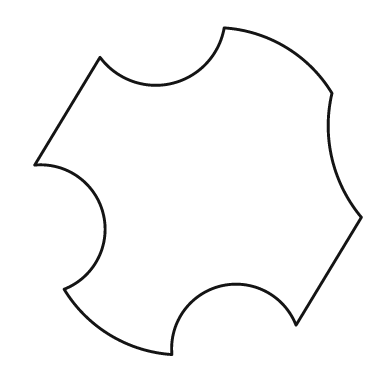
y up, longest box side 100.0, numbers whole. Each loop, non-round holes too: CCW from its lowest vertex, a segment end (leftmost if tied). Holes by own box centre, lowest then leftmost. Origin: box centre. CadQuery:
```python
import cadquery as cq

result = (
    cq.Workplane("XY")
    .moveTo(-8.0, -50.0)
    .threePointArc((7.0, -29.0), (30.0, -41.0))
    .lineTo(50.0, -8.0)
    .threePointArc((41.0, 10.0), (41.0, 30.0))
    .threePointArc((27.0, 44.0), (8.0, 50.0))
    .threePointArc((-8.0, 33.0), (-30.0, 41.0))
    .lineTo(-50.0, 8.0)
    .threePointArc((-29.0, -7.0), (-41.0, -30.0))
    .threePointArc((-27.0, -44.0), (-8.0, -50.0))
    .close()
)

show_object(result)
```